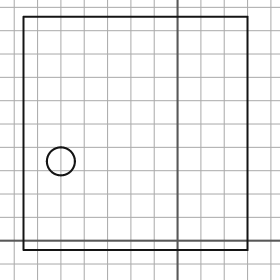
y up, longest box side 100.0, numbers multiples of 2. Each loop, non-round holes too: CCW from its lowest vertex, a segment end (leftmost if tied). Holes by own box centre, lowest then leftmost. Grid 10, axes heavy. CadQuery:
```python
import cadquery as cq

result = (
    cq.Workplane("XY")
    .moveTo(-66.0, -4.0)
    .lineTo(30.0, -4.0)
    .lineTo(30.0, 96.0)
    .lineTo(-66.0, 96.0)
    .close()
    .moveTo(-50.0, 34.0)
    .circle(6.0)
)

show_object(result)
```